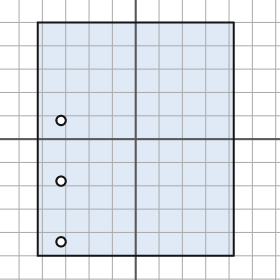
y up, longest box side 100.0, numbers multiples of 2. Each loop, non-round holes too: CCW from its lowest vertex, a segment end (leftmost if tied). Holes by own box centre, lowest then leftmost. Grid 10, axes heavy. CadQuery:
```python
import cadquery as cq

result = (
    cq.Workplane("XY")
    .moveTo(-42.0, -50.0)
    .lineTo(42.0, -50.0)
    .lineTo(42.0, 50.0)
    .lineTo(-42.0, 50.0)
    .close()
    .moveTo(-32.0, -44.0)
    .circle(2.0)
    .moveTo(-32.0, -18.0)
    .circle(2.0)
    .moveTo(-32.0, 8.0)
    .circle(2.0)
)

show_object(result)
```